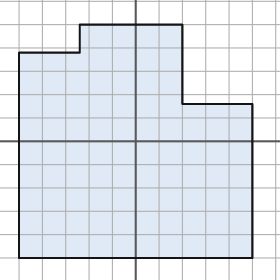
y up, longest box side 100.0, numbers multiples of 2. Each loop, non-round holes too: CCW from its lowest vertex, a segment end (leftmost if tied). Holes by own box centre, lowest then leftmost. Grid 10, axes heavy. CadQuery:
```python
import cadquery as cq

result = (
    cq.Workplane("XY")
    .moveTo(-50.0, -50.0)
    .lineTo(50.0, -50.0)
    .lineTo(50.0, 16.0)
    .lineTo(20.0, 16.0)
    .lineTo(20.0, 50.0)
    .lineTo(-24.0, 50.0)
    .lineTo(-24.0, 38.0)
    .lineTo(-50.0, 38.0)
    .close()
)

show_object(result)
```